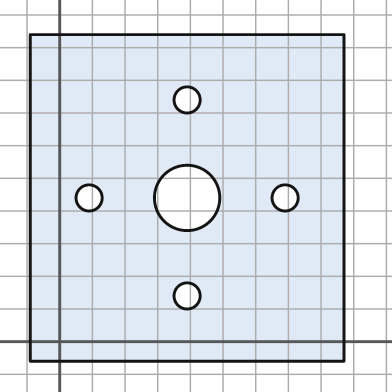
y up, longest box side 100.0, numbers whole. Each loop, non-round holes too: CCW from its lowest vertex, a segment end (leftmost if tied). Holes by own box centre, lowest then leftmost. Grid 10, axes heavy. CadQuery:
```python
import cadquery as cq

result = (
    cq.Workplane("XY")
    .moveTo(-9.0, -6.0)
    .lineTo(87.0, -6.0)
    .lineTo(87.0, 94.0)
    .lineTo(-9.0, 94.0)
    .close()
    .moveTo(39.0, 14.0)
    .circle(4.0)
    .moveTo(9.0, 44.0)
    .circle(4.0)
    .moveTo(39.0, 44.0)
    .circle(10.0)
    .moveTo(69.0, 44.0)
    .circle(4.0)
    .moveTo(39.0, 74.0)
    .circle(4.0)
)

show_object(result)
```